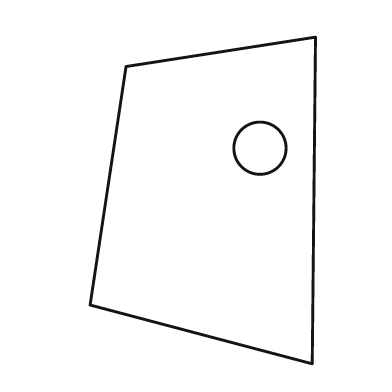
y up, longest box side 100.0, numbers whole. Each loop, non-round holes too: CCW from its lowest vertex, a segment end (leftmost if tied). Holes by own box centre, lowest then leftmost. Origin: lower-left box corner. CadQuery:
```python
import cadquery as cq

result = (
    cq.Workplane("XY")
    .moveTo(68.0, 0.0)
    .lineTo(69.0, 100.0)
    .lineTo(11.0, 91.0)
    .lineTo(0.0, 18.0)
    .close()
    .moveTo(52.0, 66.0)
    .circle(8.0)
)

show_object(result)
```